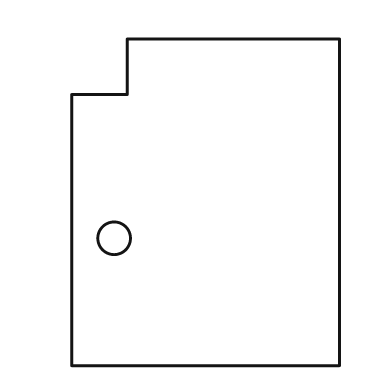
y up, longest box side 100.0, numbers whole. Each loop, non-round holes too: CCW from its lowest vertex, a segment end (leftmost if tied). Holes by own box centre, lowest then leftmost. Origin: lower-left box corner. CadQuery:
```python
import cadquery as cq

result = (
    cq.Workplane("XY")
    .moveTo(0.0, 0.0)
    .lineTo(82.0, 0.0)
    .lineTo(82.0, 100.0)
    .lineTo(17.0, 100.0)
    .lineTo(17.0, 83.0)
    .lineTo(0.0, 83.0)
    .close()
    .moveTo(13.0, 39.0)
    .circle(5.0)
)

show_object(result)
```